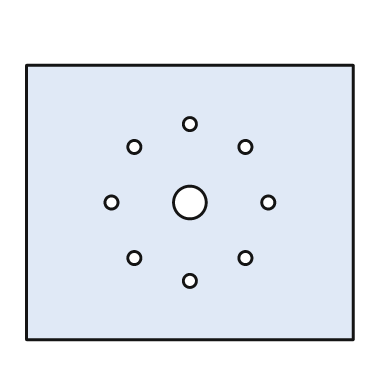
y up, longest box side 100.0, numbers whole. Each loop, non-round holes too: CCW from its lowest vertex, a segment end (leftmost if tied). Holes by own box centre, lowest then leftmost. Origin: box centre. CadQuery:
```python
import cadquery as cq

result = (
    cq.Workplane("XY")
    .moveTo(-50.0, -42.0)
    .lineTo(50.0, -42.0)
    .lineTo(50.0, 42.0)
    .lineTo(-50.0, 42.0)
    .close()
    .moveTo(0.0, -24.0)
    .circle(2.0)
    .moveTo(-17.0, -17.0)
    .circle(2.0)
    .moveTo(17.0, -17.0)
    .circle(2.0)
    .moveTo(-24.0, 0.0)
    .circle(2.0)
    .moveTo(0.0, 0.0)
    .circle(5.0)
    .moveTo(24.0, 0.0)
    .circle(2.0)
    .moveTo(-17.0, 17.0)
    .circle(2.0)
    .moveTo(17.0, 17.0)
    .circle(2.0)
    .moveTo(0.0, 24.0)
    .circle(2.0)
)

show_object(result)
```